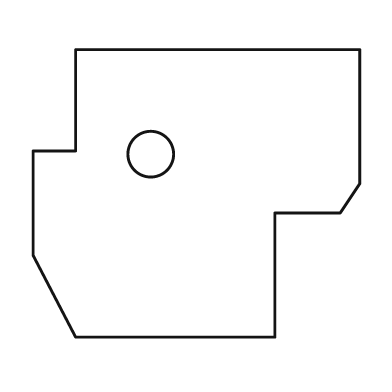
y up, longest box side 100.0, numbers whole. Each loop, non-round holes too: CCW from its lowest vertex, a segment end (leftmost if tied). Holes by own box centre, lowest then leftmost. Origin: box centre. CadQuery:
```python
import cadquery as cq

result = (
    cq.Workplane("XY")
    .moveTo(-37.0, -44.0)
    .lineTo(24.0, -44.0)
    .lineTo(24.0, -6.0)
    .lineTo(44.0, -6.0)
    .lineTo(50.0, 3.0)
    .lineTo(50.0, 44.0)
    .lineTo(-37.0, 44.0)
    .lineTo(-37.0, 13.0)
    .lineTo(-50.0, 13.0)
    .lineTo(-50.0, -19.0)
    .close()
    .moveTo(-14.0, 12.0)
    .circle(7.0)
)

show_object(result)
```